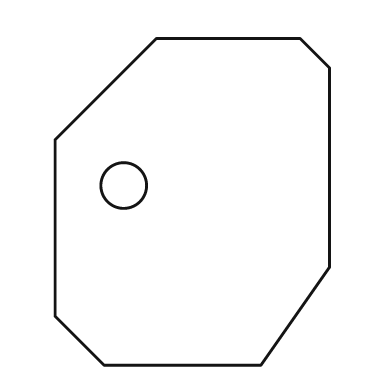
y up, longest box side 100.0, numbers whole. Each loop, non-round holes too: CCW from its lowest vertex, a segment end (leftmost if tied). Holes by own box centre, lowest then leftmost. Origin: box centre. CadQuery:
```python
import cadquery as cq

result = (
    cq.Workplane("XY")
    .moveTo(-27.0, -50.0)
    .lineTo(21.0, -50.0)
    .lineTo(42.0, -20.0)
    .lineTo(42.0, 41.0)
    .lineTo(33.0, 50.0)
    .lineTo(-11.0, 50.0)
    .lineTo(-42.0, 19.0)
    .lineTo(-42.0, -35.0)
    .close()
    .moveTo(-21.0, 5.0)
    .circle(7.0)
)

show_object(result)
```